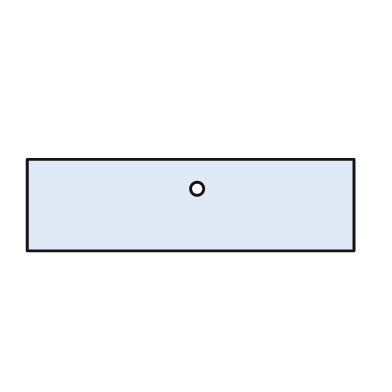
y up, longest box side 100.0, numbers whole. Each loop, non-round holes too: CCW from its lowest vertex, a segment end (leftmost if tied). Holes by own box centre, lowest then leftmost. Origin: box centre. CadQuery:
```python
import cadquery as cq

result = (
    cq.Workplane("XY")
    .moveTo(-50.0, -14.0)
    .lineTo(50.0, -14.0)
    .lineTo(50.0, 14.0)
    .lineTo(-50.0, 14.0)
    .close()
    .moveTo(2.0, 5.0)
    .circle(2.0)
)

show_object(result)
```